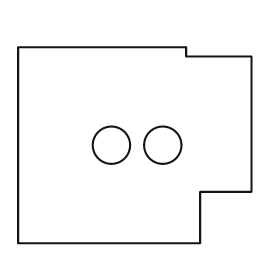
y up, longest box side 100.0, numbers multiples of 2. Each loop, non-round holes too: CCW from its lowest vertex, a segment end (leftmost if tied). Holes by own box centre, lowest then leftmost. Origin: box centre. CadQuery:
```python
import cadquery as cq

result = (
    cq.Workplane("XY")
    .moveTo(-50.0, -42.0)
    .lineTo(28.0, -42.0)
    .lineTo(28.0, -20.0)
    .lineTo(50.0, -20.0)
    .lineTo(50.0, 38.0)
    .lineTo(22.0, 38.0)
    .lineTo(22.0, 42.0)
    .lineTo(-50.0, 42.0)
    .close()
    .moveTo(-10.0, 0.0)
    .circle(8.0)
    .moveTo(12.0, 0.0)
    .circle(8.0)
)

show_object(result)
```